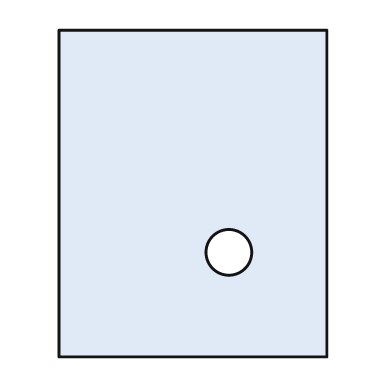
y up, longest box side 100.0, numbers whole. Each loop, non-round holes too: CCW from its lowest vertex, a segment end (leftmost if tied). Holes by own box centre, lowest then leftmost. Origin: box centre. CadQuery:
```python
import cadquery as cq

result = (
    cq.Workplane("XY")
    .moveTo(-41.0, -50.0)
    .lineTo(41.0, -50.0)
    .lineTo(41.0, 50.0)
    .lineTo(-41.0, 50.0)
    .close()
    .moveTo(11.0, -18.0)
    .circle(7.0)
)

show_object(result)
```